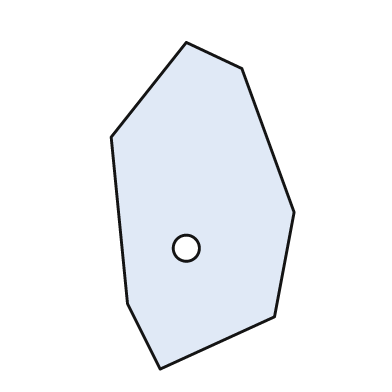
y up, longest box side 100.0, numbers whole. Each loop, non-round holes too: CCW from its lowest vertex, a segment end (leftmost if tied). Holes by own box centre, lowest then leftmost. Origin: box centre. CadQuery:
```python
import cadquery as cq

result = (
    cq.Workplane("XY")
    .moveTo(-13.0, -50.0)
    .lineTo(22.0, -34.0)
    .lineTo(28.0, -2.0)
    .lineTo(12.0, 42.0)
    .lineTo(-5.0, 50.0)
    .lineTo(-28.0, 21.0)
    .lineTo(-23.0, -30.0)
    .close()
    .moveTo(-5.0, -13.0)
    .circle(4.0)
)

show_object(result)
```